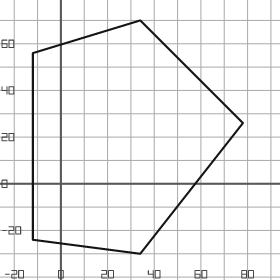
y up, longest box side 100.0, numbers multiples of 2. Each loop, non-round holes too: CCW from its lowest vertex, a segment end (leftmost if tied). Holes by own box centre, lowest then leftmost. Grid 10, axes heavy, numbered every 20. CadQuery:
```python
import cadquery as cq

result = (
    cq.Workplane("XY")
    .moveTo(34.0, -30.0)
    .lineTo(78.0, 26.0)
    .lineTo(34.0, 70.0)
    .lineTo(-12.0, 56.0)
    .lineTo(-12.0, -24.0)
    .close()
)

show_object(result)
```